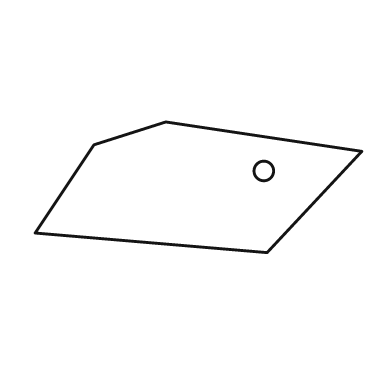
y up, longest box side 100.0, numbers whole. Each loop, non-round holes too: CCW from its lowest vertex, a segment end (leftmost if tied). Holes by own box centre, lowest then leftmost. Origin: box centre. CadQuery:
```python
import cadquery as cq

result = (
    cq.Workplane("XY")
    .moveTo(21.0, -20.0)
    .lineTo(50.0, 11.0)
    .lineTo(-10.0, 20.0)
    .lineTo(-32.0, 13.0)
    .lineTo(-50.0, -14.0)
    .close()
    .moveTo(20.0, 5.0)
    .circle(3.0)
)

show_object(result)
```